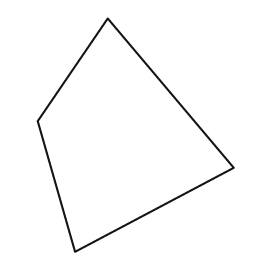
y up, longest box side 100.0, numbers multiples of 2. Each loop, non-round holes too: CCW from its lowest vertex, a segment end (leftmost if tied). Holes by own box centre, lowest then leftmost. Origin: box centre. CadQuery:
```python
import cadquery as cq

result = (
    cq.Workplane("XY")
    .moveTo(-26.0, -50.0)
    .lineTo(42.0, -14.0)
    .lineTo(-12.0, 50.0)
    .lineTo(-42.0, 6.0)
    .close()
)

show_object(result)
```